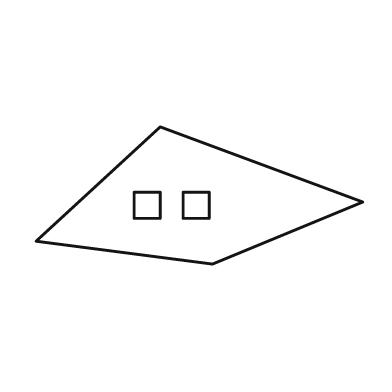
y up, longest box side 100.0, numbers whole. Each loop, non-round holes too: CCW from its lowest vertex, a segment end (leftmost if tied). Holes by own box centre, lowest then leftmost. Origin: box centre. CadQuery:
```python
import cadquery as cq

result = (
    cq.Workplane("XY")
    .moveTo(4.0, -21.0)
    .lineTo(50.0, -2.0)
    .lineTo(-12.0, 21.0)
    .lineTo(-50.0, -14.0)
    .close()
    .moveTo(-20.0, -7.0)
    .lineTo(-12.0, -7.0)
    .lineTo(-12.0, 1.0)
    .lineTo(-20.0, 1.0)
    .close()
    .moveTo(-5.0, -7.0)
    .lineTo(3.0, -7.0)
    .lineTo(3.0, 1.0)
    .lineTo(-5.0, 1.0)
    .close()
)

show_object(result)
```